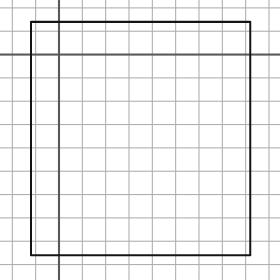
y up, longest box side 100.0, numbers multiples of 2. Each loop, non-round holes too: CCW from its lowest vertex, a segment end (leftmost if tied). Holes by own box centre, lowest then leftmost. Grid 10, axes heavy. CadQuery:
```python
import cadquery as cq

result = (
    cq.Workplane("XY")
    .moveTo(-12.0, -86.0)
    .lineTo(82.0, -86.0)
    .lineTo(82.0, 14.0)
    .lineTo(-12.0, 14.0)
    .close()
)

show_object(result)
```